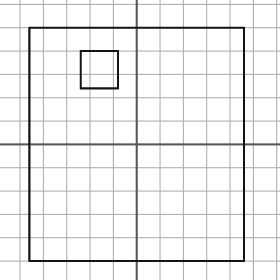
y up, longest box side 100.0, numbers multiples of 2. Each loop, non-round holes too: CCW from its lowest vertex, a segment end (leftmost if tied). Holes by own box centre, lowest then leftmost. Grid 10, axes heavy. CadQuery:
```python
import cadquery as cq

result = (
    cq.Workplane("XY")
    .moveTo(-46.0, -50.0)
    .lineTo(46.0, -50.0)
    .lineTo(46.0, 50.0)
    .lineTo(-46.0, 50.0)
    .close()
    .moveTo(-24.0, 24.0)
    .lineTo(-8.0, 24.0)
    .lineTo(-8.0, 40.0)
    .lineTo(-24.0, 40.0)
    .close()
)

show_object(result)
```